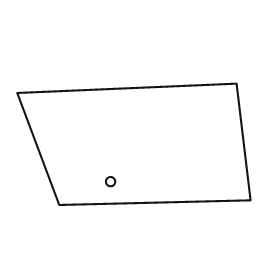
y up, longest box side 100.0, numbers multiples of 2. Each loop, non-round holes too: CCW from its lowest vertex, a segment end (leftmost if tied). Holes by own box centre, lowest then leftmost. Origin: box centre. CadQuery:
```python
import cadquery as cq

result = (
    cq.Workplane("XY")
    .moveTo(-32.0, -26.0)
    .lineTo(50.0, -24.0)
    .lineTo(44.0, 26.0)
    .lineTo(-50.0, 22.0)
    .close()
    .moveTo(-10.0, -16.0)
    .circle(2.0)
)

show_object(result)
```